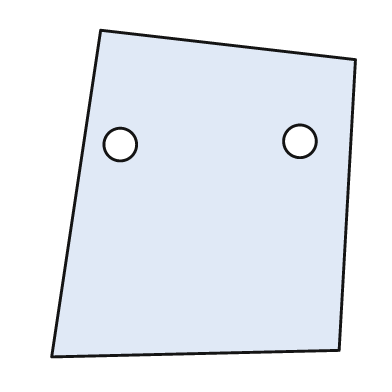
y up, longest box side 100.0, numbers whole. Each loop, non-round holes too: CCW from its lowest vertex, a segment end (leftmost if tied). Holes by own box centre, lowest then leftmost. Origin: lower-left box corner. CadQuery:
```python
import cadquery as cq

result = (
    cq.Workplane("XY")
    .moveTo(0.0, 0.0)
    .lineTo(88.0, 2.0)
    .lineTo(93.0, 91.0)
    .lineTo(15.0, 100.0)
    .close()
    .moveTo(21.0, 65.0)
    .circle(5.0)
    .moveTo(76.0, 66.0)
    .circle(5.0)
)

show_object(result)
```